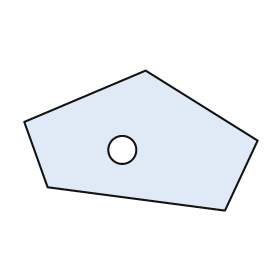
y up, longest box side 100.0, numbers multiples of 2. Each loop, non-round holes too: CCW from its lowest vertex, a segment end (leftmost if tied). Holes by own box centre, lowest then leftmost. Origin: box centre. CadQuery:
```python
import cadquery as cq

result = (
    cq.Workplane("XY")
    .moveTo(36.0, -30.0)
    .lineTo(50.0, 0.0)
    .lineTo(2.0, 30.0)
    .lineTo(-50.0, 8.0)
    .lineTo(-40.0, -20.0)
    .close()
    .moveTo(-8.0, -4.0)
    .circle(6.0)
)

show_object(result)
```